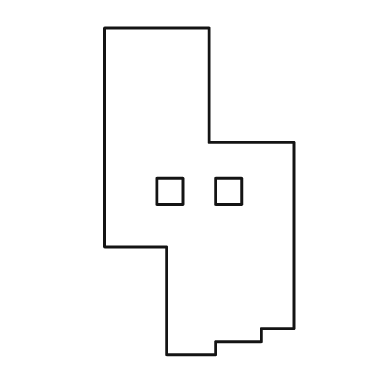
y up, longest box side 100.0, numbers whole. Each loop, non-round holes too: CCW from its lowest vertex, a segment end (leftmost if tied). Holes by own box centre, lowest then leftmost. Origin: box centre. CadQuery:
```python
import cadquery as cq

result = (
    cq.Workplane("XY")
    .moveTo(-10.0, -50.0)
    .lineTo(5.0, -50.0)
    .lineTo(5.0, -46.0)
    .lineTo(19.0, -46.0)
    .lineTo(19.0, -42.0)
    .lineTo(29.0, -42.0)
    .lineTo(29.0, 15.0)
    .lineTo(3.0, 15.0)
    .lineTo(3.0, 50.0)
    .lineTo(-29.0, 50.0)
    .lineTo(-29.0, -17.0)
    .lineTo(-10.0, -17.0)
    .close()
    .moveTo(-13.0, -4.0)
    .lineTo(-5.0, -4.0)
    .lineTo(-5.0, 4.0)
    .lineTo(-13.0, 4.0)
    .close()
    .moveTo(5.0, -4.0)
    .lineTo(13.0, -4.0)
    .lineTo(13.0, 4.0)
    .lineTo(5.0, 4.0)
    .close()
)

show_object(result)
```